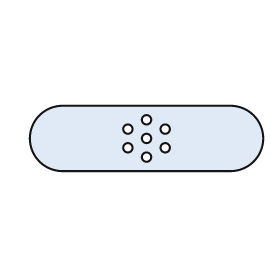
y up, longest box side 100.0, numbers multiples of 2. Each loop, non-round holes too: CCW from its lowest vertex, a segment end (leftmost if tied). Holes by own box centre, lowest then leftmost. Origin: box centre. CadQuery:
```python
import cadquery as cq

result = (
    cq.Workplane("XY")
    .moveTo(-36.0, -14.0)
    .lineTo(36.0, -14.0)
    .threePointArc((50.0, 0.0), (36.0, 14.0))
    .lineTo(-36.0, 14.0)
    .threePointArc((-50.0, 0.0), (-36.0, -14.0))
    .close()
    .moveTo(0.0, -8.0)
    .circle(2.0)
    .moveTo(-8.0, -4.0)
    .circle(2.0)
    .moveTo(8.0, -4.0)
    .circle(2.0)
    .moveTo(0.0, 0.0)
    .circle(2.0)
    .moveTo(-8.0, 4.0)
    .circle(2.0)
    .moveTo(8.0, 4.0)
    .circle(2.0)
    .moveTo(0.0, 8.0)
    .circle(2.0)
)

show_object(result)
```